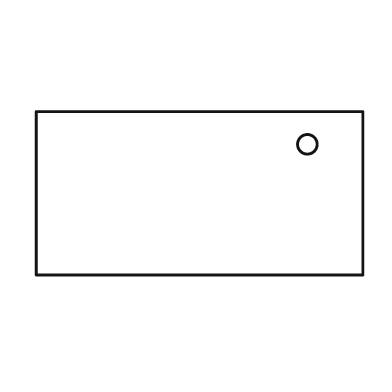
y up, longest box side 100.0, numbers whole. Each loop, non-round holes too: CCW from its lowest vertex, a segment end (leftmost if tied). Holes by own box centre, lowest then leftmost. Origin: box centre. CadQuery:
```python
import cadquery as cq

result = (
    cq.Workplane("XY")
    .moveTo(-50.0, -25.0)
    .lineTo(50.0, -25.0)
    .lineTo(50.0, 25.0)
    .lineTo(-50.0, 25.0)
    .close()
    .moveTo(33.0, 15.0)
    .circle(3.0)
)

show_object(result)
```